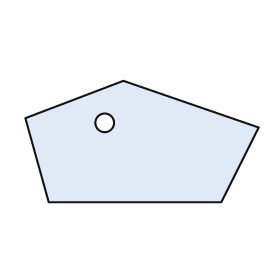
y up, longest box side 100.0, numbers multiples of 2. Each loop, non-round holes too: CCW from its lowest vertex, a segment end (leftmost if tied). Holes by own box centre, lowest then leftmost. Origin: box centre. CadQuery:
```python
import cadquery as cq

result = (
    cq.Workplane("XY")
    .moveTo(-40.0, -26.0)
    .lineTo(34.0, -26.0)
    .lineTo(50.0, 6.0)
    .lineTo(-8.0, 26.0)
    .lineTo(-50.0, 10.0)
    .close()
    .moveTo(-16.0, 8.0)
    .circle(4.0)
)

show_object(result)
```